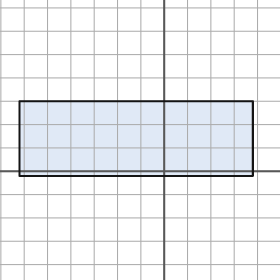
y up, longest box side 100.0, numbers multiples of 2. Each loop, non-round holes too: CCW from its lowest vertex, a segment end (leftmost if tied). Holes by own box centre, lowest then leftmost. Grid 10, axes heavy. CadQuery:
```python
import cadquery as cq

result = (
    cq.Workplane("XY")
    .moveTo(-62.0, -2.0)
    .lineTo(38.0, -2.0)
    .lineTo(38.0, 30.0)
    .lineTo(-62.0, 30.0)
    .close()
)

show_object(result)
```